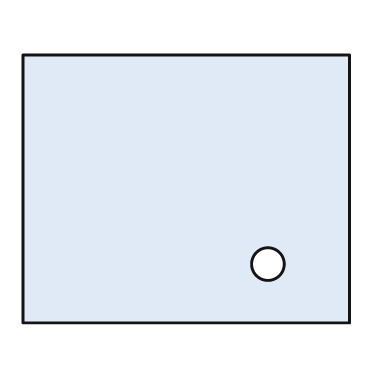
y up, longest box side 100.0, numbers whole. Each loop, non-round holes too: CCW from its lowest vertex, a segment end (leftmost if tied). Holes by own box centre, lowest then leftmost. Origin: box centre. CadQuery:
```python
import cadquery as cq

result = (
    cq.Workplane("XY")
    .moveTo(-50.0, -41.0)
    .lineTo(50.0, -41.0)
    .lineTo(50.0, 41.0)
    .lineTo(-50.0, 41.0)
    .close()
    .moveTo(25.0, -23.0)
    .circle(5.0)
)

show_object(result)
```